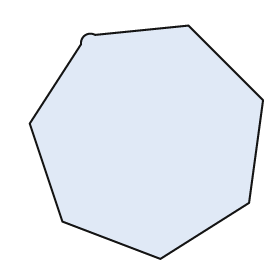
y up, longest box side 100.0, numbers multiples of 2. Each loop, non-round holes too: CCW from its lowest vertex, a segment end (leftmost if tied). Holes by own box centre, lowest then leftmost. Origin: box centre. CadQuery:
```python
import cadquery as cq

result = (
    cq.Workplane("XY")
    .moveTo(6.0, -50.0)
    .lineTo(44.0, -26.0)
    .lineTo(50.0, 18.0)
    .lineTo(18.0, 50.0)
    .lineTo(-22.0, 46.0)
    .threePointArc((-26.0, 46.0), (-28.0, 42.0))
    .lineTo(-50.0, 8.0)
    .lineTo(-36.0, -34.0)
    .close()
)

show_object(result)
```